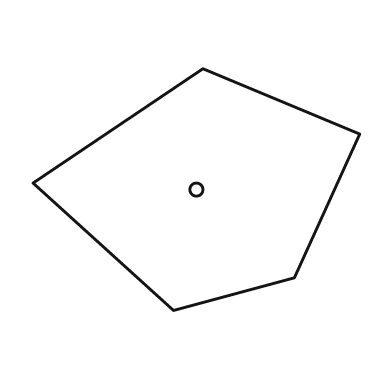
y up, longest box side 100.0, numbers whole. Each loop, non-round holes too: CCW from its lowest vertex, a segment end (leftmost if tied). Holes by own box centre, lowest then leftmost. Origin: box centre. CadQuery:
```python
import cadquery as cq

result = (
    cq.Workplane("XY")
    .moveTo(-7.0, -37.0)
    .lineTo(30.0, -27.0)
    .lineTo(50.0, 17.0)
    .lineTo(2.0, 37.0)
    .lineTo(-50.0, 2.0)
    .close()
    .moveTo(0.0, 0.0)
    .circle(2.0)
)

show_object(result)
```